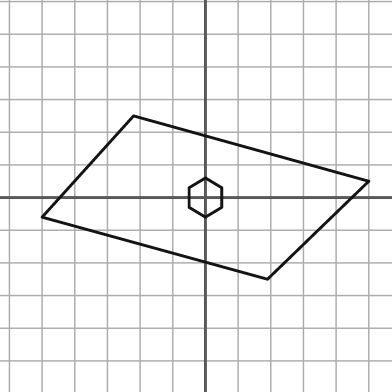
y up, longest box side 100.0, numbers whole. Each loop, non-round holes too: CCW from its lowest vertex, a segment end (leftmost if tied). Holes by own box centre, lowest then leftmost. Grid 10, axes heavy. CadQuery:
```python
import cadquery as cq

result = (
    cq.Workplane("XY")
    .moveTo(19.0, -25.0)
    .lineTo(50.0, 5.0)
    .lineTo(-22.0, 25.0)
    .lineTo(-50.0, -6.0)
    .close()
    .moveTo(0.0, -6.0)
    .lineTo(5.0, -3.0)
    .lineTo(5.0, 3.0)
    .lineTo(0.0, 6.0)
    .lineTo(-5.0, 3.0)
    .lineTo(-5.0, -3.0)
    .close()
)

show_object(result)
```